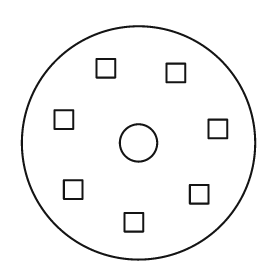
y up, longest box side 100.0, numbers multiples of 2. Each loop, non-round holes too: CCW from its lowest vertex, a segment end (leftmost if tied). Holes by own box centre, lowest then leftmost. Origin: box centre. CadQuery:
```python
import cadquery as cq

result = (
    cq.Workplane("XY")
    .moveTo(0.0, 0.0)
    .circle(50.0)
    .moveTo(-6.0, -38.0)
    .lineTo(2.0, -38.0)
    .lineTo(2.0, -30.0)
    .lineTo(-6.0, -30.0)
    .close()
    .moveTo(22.0, -26.0)
    .lineTo(30.0, -26.0)
    .lineTo(30.0, -18.0)
    .lineTo(22.0, -18.0)
    .close()
    .moveTo(-32.0, -24.0)
    .lineTo(-24.0, -24.0)
    .lineTo(-24.0, -16.0)
    .lineTo(-32.0, -16.0)
    .close()
    .moveTo(0.0, 0.0)
    .circle(8.0)
    .moveTo(30.0, 2.0)
    .lineTo(38.0, 2.0)
    .lineTo(38.0, 10.0)
    .lineTo(30.0, 10.0)
    .close()
    .moveTo(-36.0, 6.0)
    .lineTo(-28.0, 6.0)
    .lineTo(-28.0, 14.0)
    .lineTo(-36.0, 14.0)
    .close()
    .moveTo(12.0, 26.0)
    .lineTo(20.0, 26.0)
    .lineTo(20.0, 34.0)
    .lineTo(12.0, 34.0)
    .close()
    .moveTo(-18.0, 28.0)
    .lineTo(-10.0, 28.0)
    .lineTo(-10.0, 36.0)
    .lineTo(-18.0, 36.0)
    .close()
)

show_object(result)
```